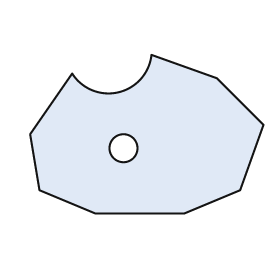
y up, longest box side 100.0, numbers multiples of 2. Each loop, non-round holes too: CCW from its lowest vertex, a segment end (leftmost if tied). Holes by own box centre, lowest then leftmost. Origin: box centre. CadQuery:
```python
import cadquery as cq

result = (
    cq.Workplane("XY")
    .moveTo(-22.0, -34.0)
    .lineTo(16.0, -34.0)
    .lineTo(40.0, -24.0)
    .lineTo(50.0, 4.0)
    .lineTo(30.0, 24.0)
    .lineTo(2.0, 34.0)
    .threePointArc((-12.0, 18.0), (-32.0, 26.0))
    .lineTo(-50.0, 0.0)
    .lineTo(-46.0, -24.0)
    .close()
    .moveTo(-10.0, -6.0)
    .circle(6.0)
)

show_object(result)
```